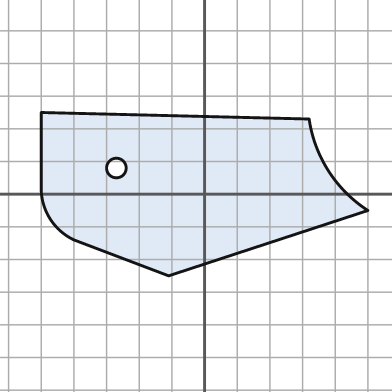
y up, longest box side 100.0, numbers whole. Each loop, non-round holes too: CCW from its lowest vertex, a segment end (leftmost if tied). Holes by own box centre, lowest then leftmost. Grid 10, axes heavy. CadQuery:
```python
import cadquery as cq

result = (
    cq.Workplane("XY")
    .moveTo(-11.0, -25.0)
    .lineTo(50.0, -5.0)
    .threePointArc((38.0, 7.0), (32.0, 23.0))
    .lineTo(-50.0, 25.0)
    .lineTo(-50.0, 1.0)
    .threePointArc((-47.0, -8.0), (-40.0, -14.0))
    .close()
    .moveTo(-27.0, 8.0)
    .circle(3.0)
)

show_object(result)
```